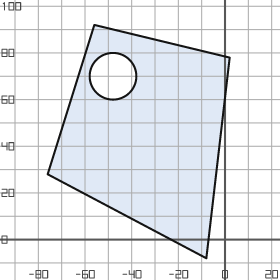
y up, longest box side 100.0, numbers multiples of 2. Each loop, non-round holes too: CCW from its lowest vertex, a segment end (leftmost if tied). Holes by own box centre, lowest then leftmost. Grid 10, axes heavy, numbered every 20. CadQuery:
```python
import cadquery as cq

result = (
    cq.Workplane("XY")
    .moveTo(-8.0, -8.0)
    .lineTo(2.0, 78.0)
    .lineTo(-56.0, 92.0)
    .lineTo(-76.0, 28.0)
    .close()
    .moveTo(-48.0, 70.0)
    .circle(10.0)
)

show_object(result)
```